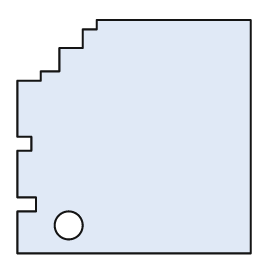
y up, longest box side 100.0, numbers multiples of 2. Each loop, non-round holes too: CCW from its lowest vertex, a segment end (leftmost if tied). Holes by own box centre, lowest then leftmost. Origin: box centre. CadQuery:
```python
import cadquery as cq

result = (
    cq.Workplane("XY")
    .moveTo(-50.0, -50.0)
    .lineTo(50.0, -50.0)
    .lineTo(50.0, 50.0)
    .lineTo(-16.0, 50.0)
    .lineTo(-16.0, 46.0)
    .lineTo(-22.0, 46.0)
    .lineTo(-22.0, 38.0)
    .lineTo(-32.0, 38.0)
    .lineTo(-32.0, 28.0)
    .lineTo(-40.0, 28.0)
    .lineTo(-40.0, 24.0)
    .lineTo(-50.0, 24.0)
    .lineTo(-50.0, 0.0)
    .lineTo(-44.0, 0.0)
    .lineTo(-44.0, -6.0)
    .lineTo(-50.0, -6.0)
    .lineTo(-50.0, -26.0)
    .lineTo(-42.0, -26.0)
    .lineTo(-42.0, -32.0)
    .lineTo(-50.0, -32.0)
    .close()
    .moveTo(-28.0, -38.0)
    .circle(6.0)
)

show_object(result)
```